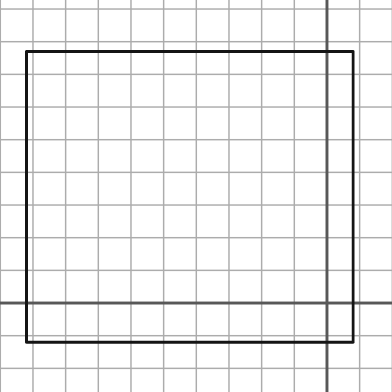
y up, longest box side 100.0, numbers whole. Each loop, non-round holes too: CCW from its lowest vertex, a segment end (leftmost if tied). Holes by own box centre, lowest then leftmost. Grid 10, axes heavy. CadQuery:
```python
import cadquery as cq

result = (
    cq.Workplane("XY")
    .moveTo(-92.0, -12.0)
    .lineTo(8.0, -12.0)
    .lineTo(8.0, 77.0)
    .lineTo(-92.0, 77.0)
    .close()
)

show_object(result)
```